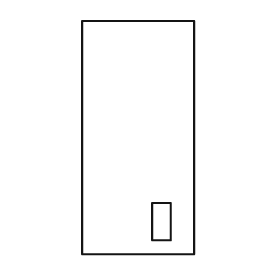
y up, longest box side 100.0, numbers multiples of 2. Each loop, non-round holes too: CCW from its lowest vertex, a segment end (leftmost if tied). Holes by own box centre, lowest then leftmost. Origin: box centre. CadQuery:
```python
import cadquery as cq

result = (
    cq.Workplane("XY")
    .moveTo(-24.0, -50.0)
    .lineTo(24.0, -50.0)
    .lineTo(24.0, 50.0)
    .lineTo(-24.0, 50.0)
    .close()
    .moveTo(6.0, -44.0)
    .lineTo(14.0, -44.0)
    .lineTo(14.0, -28.0)
    .lineTo(6.0, -28.0)
    .close()
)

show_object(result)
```